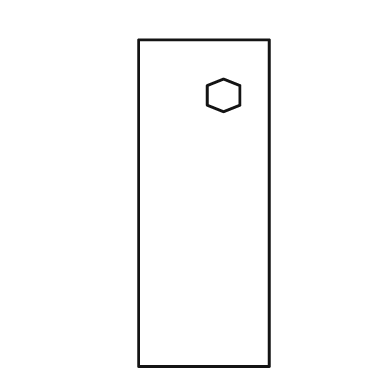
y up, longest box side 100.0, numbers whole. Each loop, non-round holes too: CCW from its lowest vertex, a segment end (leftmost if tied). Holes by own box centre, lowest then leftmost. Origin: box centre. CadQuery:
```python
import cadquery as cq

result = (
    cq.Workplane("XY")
    .moveTo(-20.0, -50.0)
    .lineTo(20.0, -50.0)
    .lineTo(20.0, 50.0)
    .lineTo(-20.0, 50.0)
    .close()
    .moveTo(6.0, 28.0)
    .lineTo(11.0, 30.0)
    .lineTo(11.0, 36.0)
    .lineTo(6.0, 38.0)
    .lineTo(1.0, 36.0)
    .lineTo(1.0, 30.0)
    .close()
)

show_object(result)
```